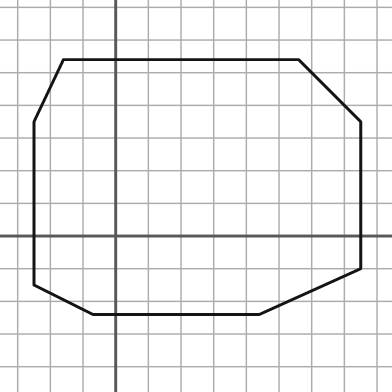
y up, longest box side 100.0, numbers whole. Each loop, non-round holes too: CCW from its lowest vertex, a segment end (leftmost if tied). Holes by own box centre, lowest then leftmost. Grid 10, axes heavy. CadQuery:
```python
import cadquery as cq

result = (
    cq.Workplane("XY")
    .moveTo(-7.0, -24.0)
    .lineTo(44.0, -24.0)
    .lineTo(75.0, -10.0)
    .lineTo(75.0, 35.0)
    .lineTo(56.0, 54.0)
    .lineTo(-16.0, 54.0)
    .lineTo(-25.0, 35.0)
    .lineTo(-25.0, -15.0)
    .close()
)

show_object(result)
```